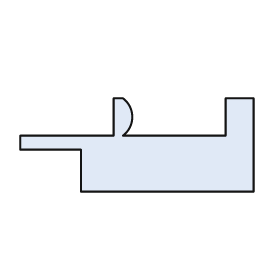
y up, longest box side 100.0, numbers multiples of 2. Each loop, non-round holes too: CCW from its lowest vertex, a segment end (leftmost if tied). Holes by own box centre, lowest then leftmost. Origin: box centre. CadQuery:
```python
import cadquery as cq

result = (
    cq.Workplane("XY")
    .moveTo(-24.0, -20.0)
    .lineTo(50.0, -20.0)
    .lineTo(50.0, 20.0)
    .lineTo(38.0, 20.0)
    .lineTo(38.0, 4.0)
    .lineTo(-6.0, 4.0)
    .threePointArc((-2.0, 12.0), (-6.0, 20.0))
    .lineTo(-10.0, 20.0)
    .lineTo(-10.0, 4.0)
    .lineTo(-50.0, 4.0)
    .lineTo(-50.0, -2.0)
    .lineTo(-24.0, -2.0)
    .close()
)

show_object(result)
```